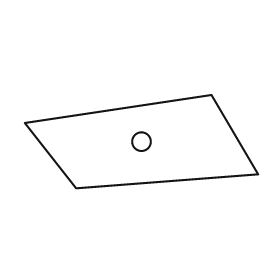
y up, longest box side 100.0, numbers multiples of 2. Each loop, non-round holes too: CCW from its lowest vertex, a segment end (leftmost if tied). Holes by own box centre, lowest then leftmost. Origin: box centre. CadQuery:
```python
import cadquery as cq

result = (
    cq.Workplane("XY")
    .moveTo(-28.0, -20.0)
    .lineTo(50.0, -14.0)
    .lineTo(30.0, 20.0)
    .lineTo(-50.0, 8.0)
    .close()
    .moveTo(0.0, 0.0)
    .circle(4.0)
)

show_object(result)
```